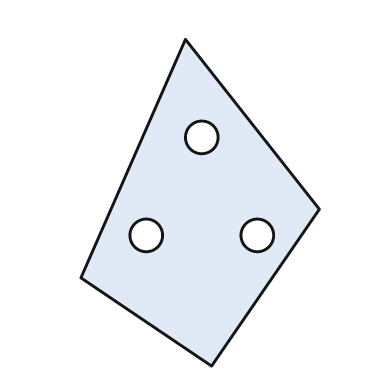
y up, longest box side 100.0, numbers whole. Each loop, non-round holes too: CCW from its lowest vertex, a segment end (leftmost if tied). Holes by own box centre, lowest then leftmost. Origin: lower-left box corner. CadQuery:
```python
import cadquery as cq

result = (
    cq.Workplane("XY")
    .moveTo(40.0, 0.0)
    .lineTo(73.0, 48.0)
    .lineTo(32.0, 100.0)
    .lineTo(0.0, 27.0)
    .close()
    .moveTo(20.0, 40.0)
    .circle(5.0)
    .moveTo(54.0, 40.0)
    .circle(5.0)
    .moveTo(37.0, 70.0)
    .circle(5.0)
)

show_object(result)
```